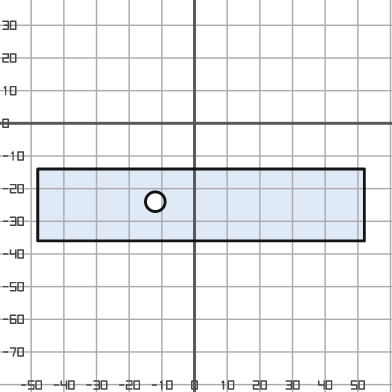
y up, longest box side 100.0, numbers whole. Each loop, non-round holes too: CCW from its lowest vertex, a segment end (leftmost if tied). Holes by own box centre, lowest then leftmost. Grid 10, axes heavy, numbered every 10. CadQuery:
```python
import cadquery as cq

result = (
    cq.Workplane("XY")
    .moveTo(-48.0, -36.0)
    .lineTo(52.0, -36.0)
    .lineTo(52.0, -14.0)
    .lineTo(-48.0, -14.0)
    .close()
    .moveTo(-12.0, -24.0)
    .circle(3.0)
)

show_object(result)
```